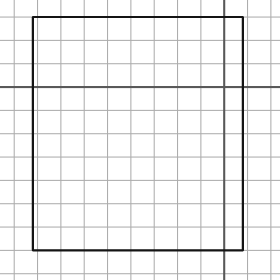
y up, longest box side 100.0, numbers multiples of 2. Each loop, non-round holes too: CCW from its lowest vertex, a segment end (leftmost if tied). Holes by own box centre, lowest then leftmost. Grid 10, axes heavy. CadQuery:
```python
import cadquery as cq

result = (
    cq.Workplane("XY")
    .moveTo(-82.0, -70.0)
    .lineTo(8.0, -70.0)
    .lineTo(8.0, 30.0)
    .lineTo(-82.0, 30.0)
    .close()
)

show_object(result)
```